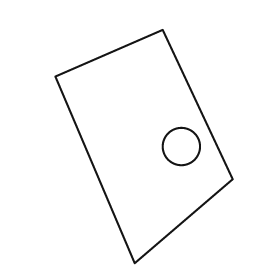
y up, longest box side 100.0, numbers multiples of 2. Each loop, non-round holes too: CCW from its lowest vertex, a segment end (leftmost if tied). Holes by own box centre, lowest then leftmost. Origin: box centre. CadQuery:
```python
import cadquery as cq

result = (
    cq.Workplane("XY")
    .moveTo(-4.0, -50.0)
    .lineTo(38.0, -14.0)
    .lineTo(8.0, 50.0)
    .lineTo(-38.0, 30.0)
    .close()
    .moveTo(16.0, 0.0)
    .circle(8.0)
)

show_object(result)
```